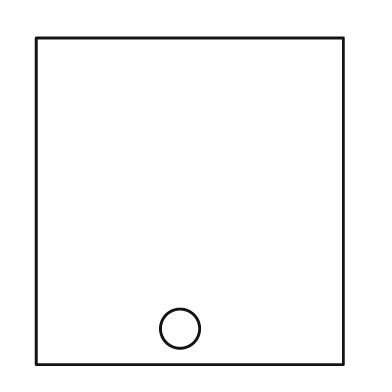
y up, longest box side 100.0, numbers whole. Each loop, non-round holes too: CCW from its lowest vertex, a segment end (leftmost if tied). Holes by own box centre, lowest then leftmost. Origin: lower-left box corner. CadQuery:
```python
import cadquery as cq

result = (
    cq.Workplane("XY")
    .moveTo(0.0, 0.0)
    .lineTo(94.0, 0.0)
    .lineTo(94.0, 100.0)
    .lineTo(0.0, 100.0)
    .close()
    .moveTo(44.0, 11.0)
    .circle(6.0)
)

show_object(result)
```